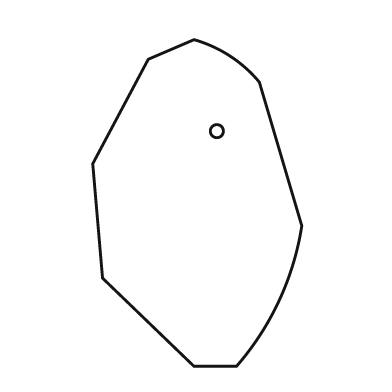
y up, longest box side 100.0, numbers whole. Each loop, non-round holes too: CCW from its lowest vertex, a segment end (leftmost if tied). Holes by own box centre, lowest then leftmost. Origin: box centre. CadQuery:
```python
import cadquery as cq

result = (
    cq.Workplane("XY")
    .moveTo(-1.0, -50.0)
    .lineTo(12.0, -50.0)
    .threePointArc((25.0, -30.0), (32.0, -7.0))
    .lineTo(19.0, 37.0)
    .threePointArc((10.0, 45.0), (-1.0, 50.0))
    .lineTo(-15.0, 44.0)
    .lineTo(-32.0, 12.0)
    .lineTo(-29.0, -23.0)
    .close()
    .moveTo(6.0, 22.0)
    .circle(2.0)
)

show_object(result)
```